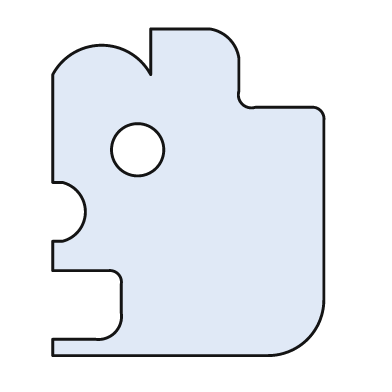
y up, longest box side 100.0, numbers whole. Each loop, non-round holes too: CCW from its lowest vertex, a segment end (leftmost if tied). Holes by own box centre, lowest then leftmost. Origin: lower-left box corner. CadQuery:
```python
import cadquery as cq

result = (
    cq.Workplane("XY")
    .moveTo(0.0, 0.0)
    .lineTo(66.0, 0.0)
    .threePointArc((78.0, 5.0), (83.0, 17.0))
    .lineTo(83.0, 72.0)
    .threePointArc((82.0, 75.0), (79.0, 76.0))
    .lineTo(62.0, 76.0)
    .threePointArc((58.0, 77.0), (57.0, 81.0))
    .lineTo(57.0, 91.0)
    .threePointArc((54.0, 97.0), (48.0, 100.0))
    .lineTo(30.0, 100.0)
    .lineTo(30.0, 86.0)
    .threePointArc((15.0, 95.0), (0.0, 86.0))
    .lineTo(0.0, 53.0)
    .lineTo(3.0, 53.0)
    .threePointArc((10.0, 44.0), (3.0, 35.0))
    .lineTo(0.0, 35.0)
    .lineTo(0.0, 26.0)
    .lineTo(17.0, 26.0)
    .threePointArc((20.0, 25.0), (21.0, 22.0))
    .lineTo(21.0, 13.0)
    .threePointArc((19.0, 7.0), (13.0, 5.0))
    .lineTo(0.0, 5.0)
    .close()
    .moveTo(26.0, 63.0)
    .circle(8.0)
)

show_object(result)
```